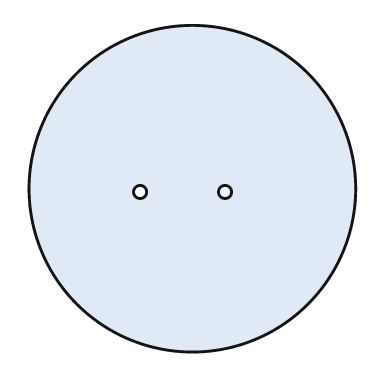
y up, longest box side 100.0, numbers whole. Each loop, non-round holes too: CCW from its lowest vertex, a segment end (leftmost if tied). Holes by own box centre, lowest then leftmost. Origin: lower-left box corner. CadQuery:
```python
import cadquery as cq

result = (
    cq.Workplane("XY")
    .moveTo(50.0, 50.0)
    .circle(50.0)
    .moveTo(34.0, 49.0)
    .circle(2.0)
    .moveTo(60.0, 49.0)
    .circle(2.0)
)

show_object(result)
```